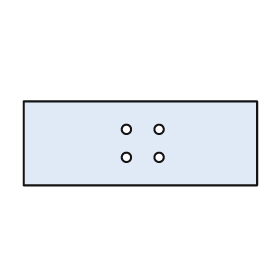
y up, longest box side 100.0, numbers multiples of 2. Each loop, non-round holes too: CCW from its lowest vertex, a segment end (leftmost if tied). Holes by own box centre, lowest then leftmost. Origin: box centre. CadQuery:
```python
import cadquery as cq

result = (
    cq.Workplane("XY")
    .moveTo(-50.0, -18.0)
    .lineTo(50.0, -18.0)
    .lineTo(50.0, 18.0)
    .lineTo(-50.0, 18.0)
    .close()
    .moveTo(-6.0, -6.0)
    .circle(2.0)
    .moveTo(8.0, -6.0)
    .circle(2.0)
    .moveTo(-6.0, 6.0)
    .circle(2.0)
    .moveTo(8.0, 6.0)
    .circle(2.0)
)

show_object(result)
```